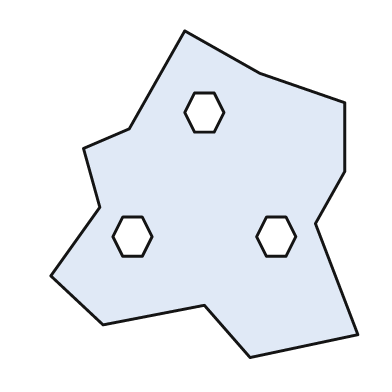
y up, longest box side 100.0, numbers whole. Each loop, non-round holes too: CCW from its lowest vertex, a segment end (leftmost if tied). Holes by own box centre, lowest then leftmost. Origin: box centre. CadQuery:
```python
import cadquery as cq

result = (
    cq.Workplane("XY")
    .moveTo(14.0, -50.0)
    .lineTo(47.0, -43.0)
    .lineTo(34.0, -9.0)
    .lineTo(43.0, 7.0)
    .lineTo(43.0, 28.0)
    .lineTo(17.0, 37.0)
    .lineTo(-6.0, 50.0)
    .lineTo(-23.0, 20.0)
    .lineTo(-37.0, 14.0)
    .lineTo(-32.0, -4.0)
    .lineTo(-47.0, -25.0)
    .lineTo(-31.0, -40.0)
    .lineTo(0.0, -34.0)
    .close()
    .moveTo(-25.0, -19.0)
    .lineTo(-19.0, -19.0)
    .lineTo(-16.0, -13.0)
    .lineTo(-19.0, -7.0)
    .lineTo(-25.0, -7.0)
    .lineTo(-28.0, -13.0)
    .close()
    .moveTo(19.0, -19.0)
    .lineTo(25.0, -19.0)
    .lineTo(28.0, -13.0)
    .lineTo(25.0, -7.0)
    .lineTo(19.0, -7.0)
    .lineTo(16.0, -13.0)
    .close()
    .moveTo(-3.0, 19.0)
    .lineTo(3.0, 19.0)
    .lineTo(6.0, 25.0)
    .lineTo(3.0, 31.0)
    .lineTo(-3.0, 31.0)
    .lineTo(-6.0, 25.0)
    .close()
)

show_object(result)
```